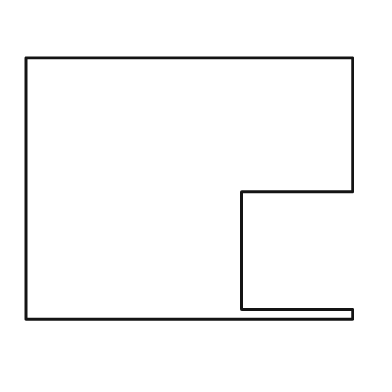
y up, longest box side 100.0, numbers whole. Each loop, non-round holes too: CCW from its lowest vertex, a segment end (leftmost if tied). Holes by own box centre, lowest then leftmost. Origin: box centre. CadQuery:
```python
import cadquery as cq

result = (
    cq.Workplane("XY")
    .moveTo(-50.0, -40.0)
    .lineTo(50.0, -40.0)
    .lineTo(50.0, -37.0)
    .lineTo(16.0, -37.0)
    .lineTo(16.0, -1.0)
    .lineTo(50.0, -1.0)
    .lineTo(50.0, 40.0)
    .lineTo(-50.0, 40.0)
    .close()
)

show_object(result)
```